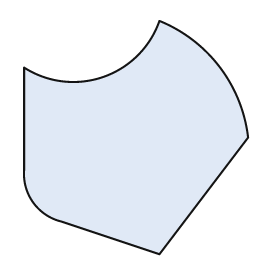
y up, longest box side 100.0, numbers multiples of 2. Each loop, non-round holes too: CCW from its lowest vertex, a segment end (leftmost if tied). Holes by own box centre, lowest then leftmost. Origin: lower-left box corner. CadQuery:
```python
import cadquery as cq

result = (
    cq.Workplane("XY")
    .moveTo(58.0, 0.0)
    .lineTo(96.0, 50.0)
    .threePointArc((84.0, 80.0), (58.0, 100.0))
    .threePointArc((34.0, 76.0), (0.0, 80.0))
    .lineTo(0.0, 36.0)
    .threePointArc((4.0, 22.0), (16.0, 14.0))
    .close()
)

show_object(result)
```